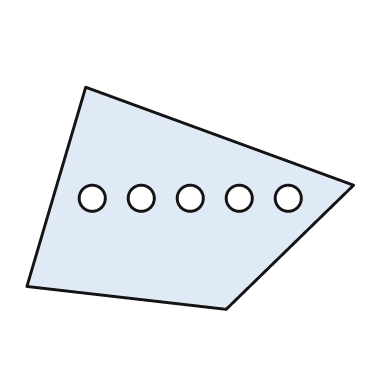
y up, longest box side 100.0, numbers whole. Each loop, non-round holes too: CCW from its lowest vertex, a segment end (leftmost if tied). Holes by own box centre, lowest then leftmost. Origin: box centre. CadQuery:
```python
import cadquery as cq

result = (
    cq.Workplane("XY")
    .moveTo(11.0, -34.0)
    .lineTo(50.0, 4.0)
    .lineTo(-32.0, 34.0)
    .lineTo(-50.0, -27.0)
    .close()
    .moveTo(-30.0, 0.0)
    .circle(4.0)
    .moveTo(-15.0, 0.0)
    .circle(4.0)
    .moveTo(0.0, 0.0)
    .circle(4.0)
    .moveTo(15.0, 0.0)
    .circle(4.0)
    .moveTo(30.0, 0.0)
    .circle(4.0)
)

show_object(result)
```